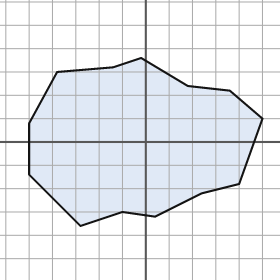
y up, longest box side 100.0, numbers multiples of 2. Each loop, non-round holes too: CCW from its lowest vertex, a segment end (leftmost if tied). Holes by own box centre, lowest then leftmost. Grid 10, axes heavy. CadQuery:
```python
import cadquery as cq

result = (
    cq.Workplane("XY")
    .moveTo(-28.0, -36.0)
    .lineTo(-10.0, -30.0)
    .lineTo(4.0, -32.0)
    .lineTo(24.0, -22.0)
    .lineTo(40.0, -18.0)
    .lineTo(50.0, 10.0)
    .lineTo(36.0, 22.0)
    .lineTo(18.0, 24.0)
    .lineTo(-2.0, 36.0)
    .lineTo(-14.0, 32.0)
    .lineTo(-38.0, 30.0)
    .lineTo(-50.0, 8.0)
    .lineTo(-50.0, -14.0)
    .close()
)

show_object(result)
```